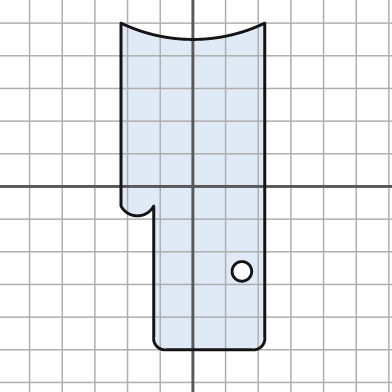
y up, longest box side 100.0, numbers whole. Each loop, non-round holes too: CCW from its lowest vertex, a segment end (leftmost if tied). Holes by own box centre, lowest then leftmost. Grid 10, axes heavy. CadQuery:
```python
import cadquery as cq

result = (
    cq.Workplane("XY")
    .moveTo(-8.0, -50.0)
    .lineTo(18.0, -50.0)
    .threePointArc((21.0, -49.0), (22.0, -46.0))
    .lineTo(22.0, 50.0)
    .threePointArc((0.0, 45.0), (-22.0, 50.0))
    .lineTo(-22.0, -6.0)
    .threePointArc((-17.0, -9.0), (-12.0, -6.0))
    .lineTo(-12.0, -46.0)
    .threePointArc((-11.0, -49.0), (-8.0, -50.0))
    .close()
    .moveTo(15.0, -26.0)
    .circle(3.0)
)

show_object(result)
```